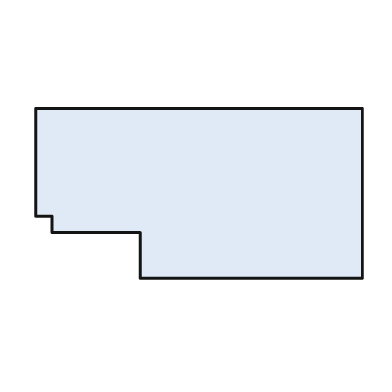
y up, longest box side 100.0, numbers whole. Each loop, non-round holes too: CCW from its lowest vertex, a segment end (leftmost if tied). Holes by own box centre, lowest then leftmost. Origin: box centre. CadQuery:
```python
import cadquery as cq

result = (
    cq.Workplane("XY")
    .moveTo(-18.0, -26.0)
    .lineTo(50.0, -26.0)
    .lineTo(50.0, 26.0)
    .lineTo(-50.0, 26.0)
    .lineTo(-50.0, -7.0)
    .lineTo(-45.0, -7.0)
    .lineTo(-45.0, -12.0)
    .lineTo(-18.0, -12.0)
    .close()
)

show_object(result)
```